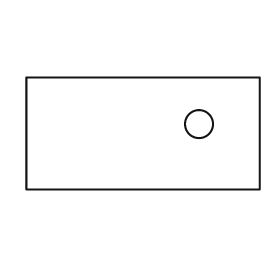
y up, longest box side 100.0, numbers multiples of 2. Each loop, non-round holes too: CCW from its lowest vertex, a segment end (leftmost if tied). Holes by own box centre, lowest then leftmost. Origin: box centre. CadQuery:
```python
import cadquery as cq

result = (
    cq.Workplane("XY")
    .moveTo(-50.0, -24.0)
    .lineTo(50.0, -24.0)
    .lineTo(50.0, 24.0)
    .lineTo(-50.0, 24.0)
    .close()
    .moveTo(24.0, 4.0)
    .circle(6.0)
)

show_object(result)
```